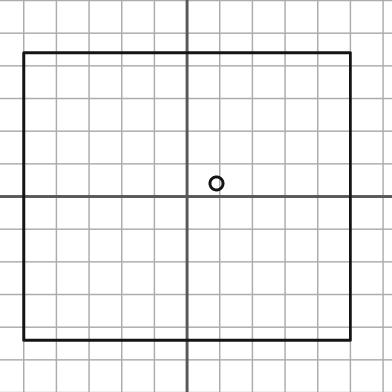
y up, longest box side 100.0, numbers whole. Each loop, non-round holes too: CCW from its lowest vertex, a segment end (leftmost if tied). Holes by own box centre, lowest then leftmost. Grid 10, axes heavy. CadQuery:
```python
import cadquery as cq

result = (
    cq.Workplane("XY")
    .moveTo(-50.0, -44.0)
    .lineTo(50.0, -44.0)
    .lineTo(50.0, 44.0)
    .lineTo(-50.0, 44.0)
    .close()
    .moveTo(9.0, 4.0)
    .circle(2.0)
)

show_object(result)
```